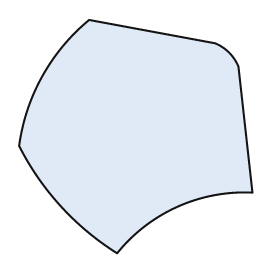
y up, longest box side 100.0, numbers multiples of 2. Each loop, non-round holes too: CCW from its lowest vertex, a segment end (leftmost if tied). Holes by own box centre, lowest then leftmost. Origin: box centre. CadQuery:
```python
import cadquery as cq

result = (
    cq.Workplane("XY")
    .moveTo(-8.0, -50.0)
    .threePointArc((18.0, -30.0), (50.0, -24.0))
    .lineTo(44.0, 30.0)
    .threePointArc((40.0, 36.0), (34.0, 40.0))
    .lineTo(-20.0, 50.0)
    .threePointArc((-40.0, 26.0), (-50.0, -4.0))
    .threePointArc((-32.0, -30.0), (-8.0, -50.0))
    .close()
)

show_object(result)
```